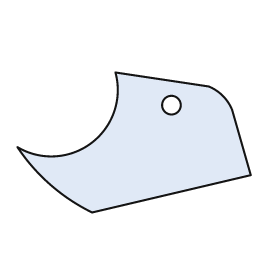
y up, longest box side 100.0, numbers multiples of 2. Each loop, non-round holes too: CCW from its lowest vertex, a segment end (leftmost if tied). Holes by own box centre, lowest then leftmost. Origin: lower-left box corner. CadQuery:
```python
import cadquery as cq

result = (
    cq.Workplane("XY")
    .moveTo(32.0, 0.0)
    .lineTo(100.0, 16.0)
    .lineTo(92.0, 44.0)
    .threePointArc((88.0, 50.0), (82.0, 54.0))
    .lineTo(42.0, 60.0)
    .threePointArc((32.0, 30.0), (0.0, 28.0))
    .threePointArc((14.0, 12.0), (32.0, 0.0))
    .close()
    .moveTo(66.0, 46.0)
    .circle(4.0)
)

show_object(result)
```